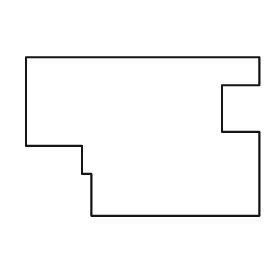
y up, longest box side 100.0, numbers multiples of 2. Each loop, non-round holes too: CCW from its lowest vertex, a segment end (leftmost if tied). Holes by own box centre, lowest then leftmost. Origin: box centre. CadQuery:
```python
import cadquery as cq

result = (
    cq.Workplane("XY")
    .moveTo(-22.0, -34.0)
    .lineTo(50.0, -34.0)
    .lineTo(50.0, 2.0)
    .lineTo(34.0, 2.0)
    .lineTo(34.0, 22.0)
    .lineTo(50.0, 22.0)
    .lineTo(50.0, 34.0)
    .lineTo(-50.0, 34.0)
    .lineTo(-50.0, -4.0)
    .lineTo(-26.0, -4.0)
    .lineTo(-26.0, -16.0)
    .lineTo(-22.0, -16.0)
    .close()
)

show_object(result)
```